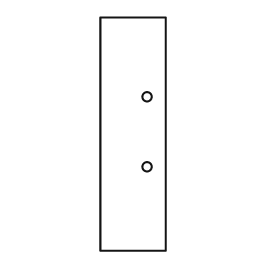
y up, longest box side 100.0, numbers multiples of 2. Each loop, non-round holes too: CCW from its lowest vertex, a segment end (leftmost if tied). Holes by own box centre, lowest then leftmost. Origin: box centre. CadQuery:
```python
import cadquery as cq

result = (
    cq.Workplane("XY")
    .moveTo(-14.0, -50.0)
    .lineTo(14.0, -50.0)
    .lineTo(14.0, 50.0)
    .lineTo(-14.0, 50.0)
    .close()
    .moveTo(6.0, -14.0)
    .circle(2.0)
    .moveTo(6.0, 16.0)
    .circle(2.0)
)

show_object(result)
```